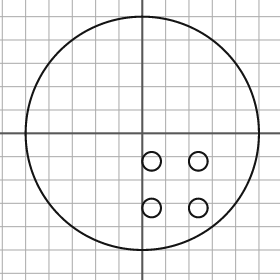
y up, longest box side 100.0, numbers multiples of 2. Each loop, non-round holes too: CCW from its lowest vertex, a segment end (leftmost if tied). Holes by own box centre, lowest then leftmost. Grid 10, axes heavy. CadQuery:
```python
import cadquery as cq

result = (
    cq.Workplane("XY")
    .moveTo(0.0, 0.0)
    .circle(50.0)
    .moveTo(4.0, -32.0)
    .circle(4.0)
    .moveTo(24.0, -32.0)
    .circle(4.0)
    .moveTo(4.0, -12.0)
    .circle(4.0)
    .moveTo(24.0, -12.0)
    .circle(4.0)
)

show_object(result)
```